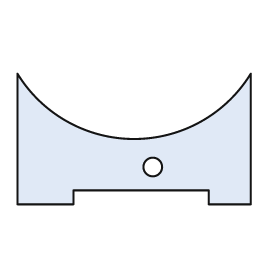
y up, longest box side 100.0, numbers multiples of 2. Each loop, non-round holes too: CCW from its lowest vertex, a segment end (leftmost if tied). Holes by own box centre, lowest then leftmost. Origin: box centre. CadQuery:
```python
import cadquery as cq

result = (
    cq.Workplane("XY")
    .moveTo(-50.0, -28.0)
    .lineTo(-26.0, -28.0)
    .lineTo(-26.0, -22.0)
    .lineTo(32.0, -22.0)
    .lineTo(32.0, -28.0)
    .lineTo(50.0, -28.0)
    .lineTo(50.0, 28.0)
    .threePointArc((0.0, 0.0), (-50.0, 28.0))
    .close()
    .moveTo(8.0, -12.0)
    .circle(4.0)
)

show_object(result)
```